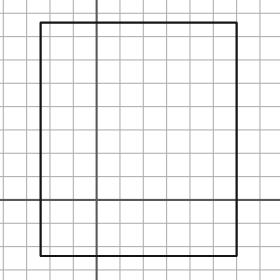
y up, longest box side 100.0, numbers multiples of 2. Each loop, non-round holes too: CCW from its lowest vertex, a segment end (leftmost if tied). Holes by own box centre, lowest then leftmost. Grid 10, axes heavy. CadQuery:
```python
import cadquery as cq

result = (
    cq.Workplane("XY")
    .moveTo(-24.0, -24.0)
    .lineTo(60.0, -24.0)
    .lineTo(60.0, 76.0)
    .lineTo(-24.0, 76.0)
    .close()
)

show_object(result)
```